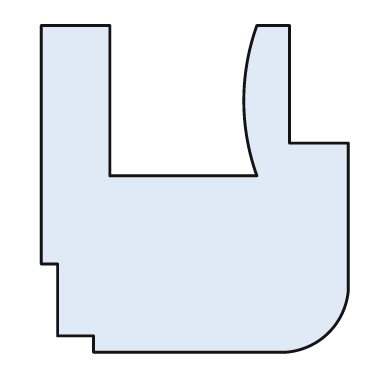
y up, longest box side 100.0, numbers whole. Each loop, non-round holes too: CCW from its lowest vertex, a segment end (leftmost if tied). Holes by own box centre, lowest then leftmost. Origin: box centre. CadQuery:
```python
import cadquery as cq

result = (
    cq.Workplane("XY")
    .moveTo(-31.0, -50.0)
    .lineTo(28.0, -50.0)
    .threePointArc((41.0, -44.0), (47.0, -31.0))
    .lineTo(47.0, 14.0)
    .lineTo(29.0, 14.0)
    .lineTo(29.0, 50.0)
    .lineTo(19.0, 50.0)
    .threePointArc((15.0, 27.0), (19.0, 4.0))
    .lineTo(-26.0, 4.0)
    .lineTo(-26.0, 50.0)
    .lineTo(-47.0, 50.0)
    .lineTo(-47.0, -23.0)
    .lineTo(-42.0, -23.0)
    .lineTo(-42.0, -45.0)
    .lineTo(-31.0, -45.0)
    .close()
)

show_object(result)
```